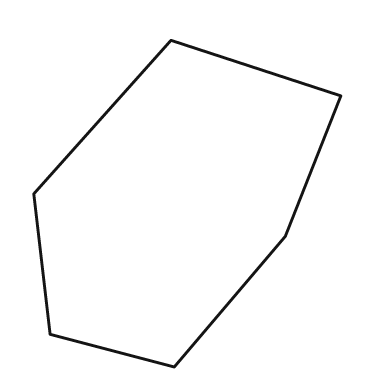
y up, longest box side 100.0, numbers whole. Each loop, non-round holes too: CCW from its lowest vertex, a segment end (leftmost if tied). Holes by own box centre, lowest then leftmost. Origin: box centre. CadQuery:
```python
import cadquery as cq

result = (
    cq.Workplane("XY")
    .moveTo(-4.0, -50.0)
    .lineTo(30.0, -10.0)
    .lineTo(47.0, 33.0)
    .lineTo(-5.0, 50.0)
    .lineTo(-47.0, 3.0)
    .lineTo(-42.0, -40.0)
    .close()
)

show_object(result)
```